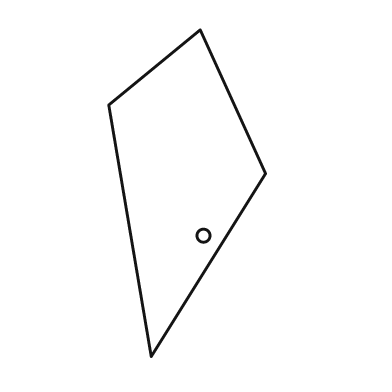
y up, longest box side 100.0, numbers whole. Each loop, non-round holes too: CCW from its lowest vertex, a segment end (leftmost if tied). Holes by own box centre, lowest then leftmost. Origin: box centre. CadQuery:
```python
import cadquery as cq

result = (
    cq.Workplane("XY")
    .moveTo(-11.0, -50.0)
    .lineTo(24.0, 6.0)
    .lineTo(4.0, 50.0)
    .lineTo(-24.0, 27.0)
    .close()
    .moveTo(5.0, -13.0)
    .circle(2.0)
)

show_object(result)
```